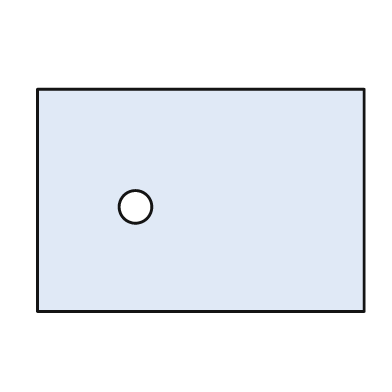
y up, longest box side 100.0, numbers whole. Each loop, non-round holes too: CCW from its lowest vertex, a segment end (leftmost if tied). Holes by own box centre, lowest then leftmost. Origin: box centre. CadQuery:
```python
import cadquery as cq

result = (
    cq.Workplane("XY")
    .moveTo(-50.0, -34.0)
    .lineTo(50.0, -34.0)
    .lineTo(50.0, 34.0)
    .lineTo(-50.0, 34.0)
    .close()
    .moveTo(-20.0, -2.0)
    .circle(5.0)
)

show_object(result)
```